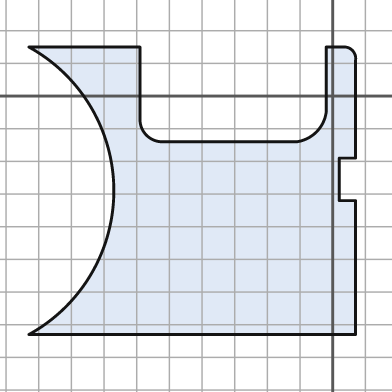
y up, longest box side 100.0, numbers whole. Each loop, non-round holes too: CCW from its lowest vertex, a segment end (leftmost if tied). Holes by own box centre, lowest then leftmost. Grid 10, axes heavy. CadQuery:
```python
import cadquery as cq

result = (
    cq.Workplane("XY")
    .moveTo(-93.0, -73.0)
    .lineTo(7.0, -73.0)
    .lineTo(7.0, -32.0)
    .lineTo(2.0, -32.0)
    .lineTo(2.0, -19.0)
    .lineTo(7.0, -19.0)
    .lineTo(7.0, 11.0)
    .threePointArc((6.0, 14.0), (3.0, 15.0))
    .lineTo(-2.0, 15.0)
    .lineTo(-2.0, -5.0)
    .threePointArc((-5.0, -11.0), (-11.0, -14.0))
    .lineTo(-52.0, -14.0)
    .threePointArc((-57.0, -12.0), (-59.0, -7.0))
    .lineTo(-59.0, 15.0)
    .lineTo(-93.0, 15.0)
    .threePointArc((-67.0, -29.0), (-93.0, -73.0))
    .close()
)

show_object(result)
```